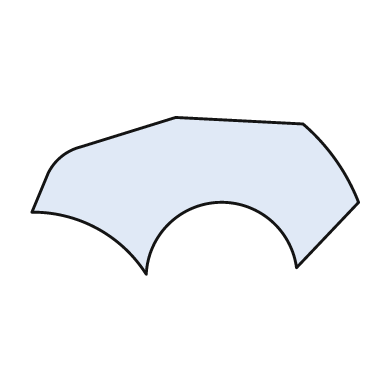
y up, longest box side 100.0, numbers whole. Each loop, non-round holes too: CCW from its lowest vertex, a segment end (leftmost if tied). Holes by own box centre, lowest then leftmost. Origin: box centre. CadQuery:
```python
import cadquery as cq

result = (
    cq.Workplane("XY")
    .moveTo(-15.0, -24.0)
    .threePointArc((7.0, -2.0), (31.0, -22.0))
    .lineTo(50.0, -2.0)
    .threePointArc((43.0, 11.0), (33.0, 22.0))
    .lineTo(-6.0, 24.0)
    .lineTo(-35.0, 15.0)
    .threePointArc((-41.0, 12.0), (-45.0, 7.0))
    .lineTo(-50.0, -5.0)
    .threePointArc((-30.0, -10.0), (-15.0, -24.0))
    .close()
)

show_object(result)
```